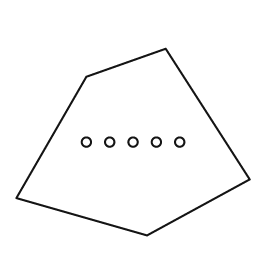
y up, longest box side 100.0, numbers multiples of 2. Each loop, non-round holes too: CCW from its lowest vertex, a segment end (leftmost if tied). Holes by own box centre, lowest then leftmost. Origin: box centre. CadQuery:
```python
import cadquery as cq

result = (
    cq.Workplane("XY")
    .moveTo(6.0, -40.0)
    .lineTo(50.0, -16.0)
    .lineTo(14.0, 40.0)
    .lineTo(-20.0, 28.0)
    .lineTo(-50.0, -24.0)
    .close()
    .moveTo(-20.0, 0.0)
    .circle(2.0)
    .moveTo(-10.0, 0.0)
    .circle(2.0)
    .moveTo(0.0, 0.0)
    .circle(2.0)
    .moveTo(10.0, 0.0)
    .circle(2.0)
    .moveTo(20.0, 0.0)
    .circle(2.0)
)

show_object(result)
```